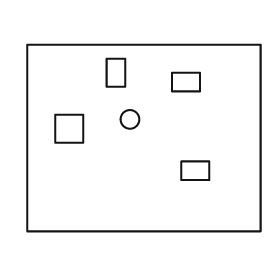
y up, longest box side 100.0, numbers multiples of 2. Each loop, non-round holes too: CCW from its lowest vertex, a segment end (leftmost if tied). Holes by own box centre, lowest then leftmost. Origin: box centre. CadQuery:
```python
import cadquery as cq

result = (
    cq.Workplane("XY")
    .moveTo(-50.0, -40.0)
    .lineTo(50.0, -40.0)
    .lineTo(50.0, 40.0)
    .lineTo(-50.0, 40.0)
    .close()
    .moveTo(16.0, -18.0)
    .lineTo(28.0, -18.0)
    .lineTo(28.0, -10.0)
    .lineTo(16.0, -10.0)
    .close()
    .moveTo(-38.0, -2.0)
    .lineTo(-26.0, -2.0)
    .lineTo(-26.0, 10.0)
    .lineTo(-38.0, 10.0)
    .close()
    .moveTo(-6.0, 8.0)
    .circle(4.0)
    .moveTo(12.0, 20.0)
    .lineTo(24.0, 20.0)
    .lineTo(24.0, 28.0)
    .lineTo(12.0, 28.0)
    .close()
    .moveTo(-16.0, 22.0)
    .lineTo(-8.0, 22.0)
    .lineTo(-8.0, 34.0)
    .lineTo(-16.0, 34.0)
    .close()
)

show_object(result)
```